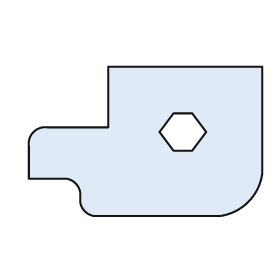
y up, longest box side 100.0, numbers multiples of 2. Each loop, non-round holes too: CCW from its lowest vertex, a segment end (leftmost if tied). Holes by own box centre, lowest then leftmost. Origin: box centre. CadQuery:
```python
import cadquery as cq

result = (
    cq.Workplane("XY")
    .moveTo(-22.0, -32.0)
    .lineTo(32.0, -32.0)
    .threePointArc((44.0, -26.0), (50.0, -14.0))
    .lineTo(50.0, 32.0)
    .lineTo(-16.0, 32.0)
    .lineTo(-16.0, 6.0)
    .lineTo(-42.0, 6.0)
    .threePointArc((-48.0, 4.0), (-50.0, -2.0))
    .lineTo(-50.0, -16.0)
    .lineTo(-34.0, -16.0)
    .threePointArc((-30.0, -18.0), (-28.0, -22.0))
    .lineTo(-28.0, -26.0)
    .threePointArc((-26.0, -30.0), (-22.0, -32.0))
    .close()
    .moveTo(12.0, -4.0)
    .lineTo(20.0, -4.0)
    .lineTo(26.0, 4.0)
    .lineTo(20.0, 12.0)
    .lineTo(12.0, 12.0)
    .lineTo(6.0, 4.0)
    .close()
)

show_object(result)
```